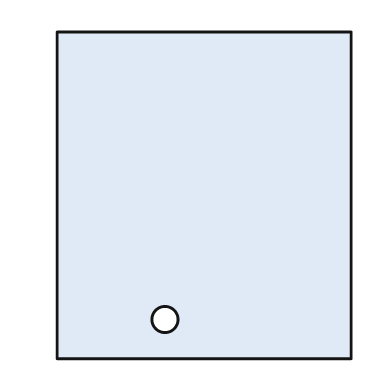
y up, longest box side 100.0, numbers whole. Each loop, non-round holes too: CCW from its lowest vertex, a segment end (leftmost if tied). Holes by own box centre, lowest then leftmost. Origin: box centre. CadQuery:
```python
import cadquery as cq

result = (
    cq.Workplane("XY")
    .moveTo(-45.0, -50.0)
    .lineTo(45.0, -50.0)
    .lineTo(45.0, 50.0)
    .lineTo(-45.0, 50.0)
    .close()
    .moveTo(-12.0, -38.0)
    .circle(4.0)
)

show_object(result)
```